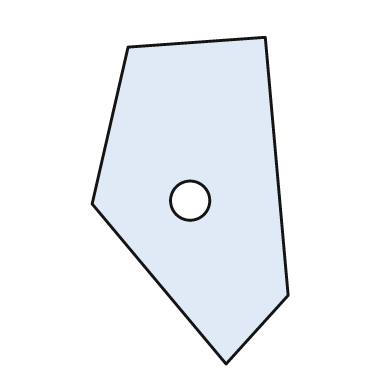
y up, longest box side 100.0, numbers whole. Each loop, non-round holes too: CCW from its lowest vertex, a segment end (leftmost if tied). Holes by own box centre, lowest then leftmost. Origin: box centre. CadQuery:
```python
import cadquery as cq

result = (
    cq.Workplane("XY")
    .moveTo(11.0, -50.0)
    .lineTo(30.0, -29.0)
    .lineTo(23.0, 50.0)
    .lineTo(-19.0, 47.0)
    .lineTo(-30.0, -1.0)
    .close()
    .moveTo(0.0, 0.0)
    .circle(6.0)
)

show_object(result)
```